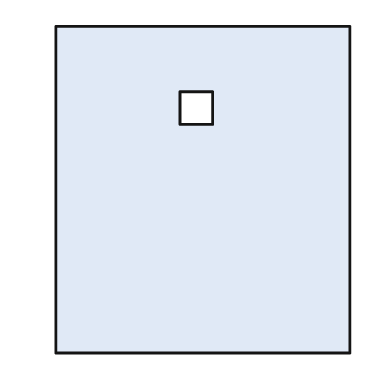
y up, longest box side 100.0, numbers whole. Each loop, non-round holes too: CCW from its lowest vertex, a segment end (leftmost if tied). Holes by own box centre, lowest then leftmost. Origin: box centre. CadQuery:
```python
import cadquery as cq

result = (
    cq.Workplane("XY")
    .moveTo(-45.0, -50.0)
    .lineTo(45.0, -50.0)
    .lineTo(45.0, 50.0)
    .lineTo(-45.0, 50.0)
    .close()
    .moveTo(-7.0, 20.0)
    .lineTo(3.0, 20.0)
    .lineTo(3.0, 30.0)
    .lineTo(-7.0, 30.0)
    .close()
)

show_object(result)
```